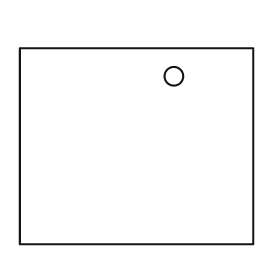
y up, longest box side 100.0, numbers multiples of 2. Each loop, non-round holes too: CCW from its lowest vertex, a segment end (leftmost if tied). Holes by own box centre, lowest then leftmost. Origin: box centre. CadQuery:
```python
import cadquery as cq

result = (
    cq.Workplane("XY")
    .moveTo(-50.0, -42.0)
    .lineTo(50.0, -42.0)
    .lineTo(50.0, 42.0)
    .lineTo(-50.0, 42.0)
    .close()
    .moveTo(16.0, 30.0)
    .circle(4.0)
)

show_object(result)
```